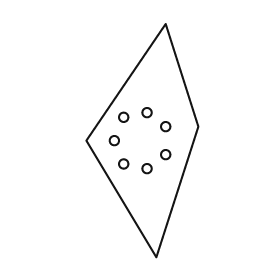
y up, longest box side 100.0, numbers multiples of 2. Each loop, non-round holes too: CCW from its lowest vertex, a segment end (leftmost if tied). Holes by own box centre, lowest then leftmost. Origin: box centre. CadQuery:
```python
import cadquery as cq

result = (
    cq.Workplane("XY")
    .moveTo(6.0, -50.0)
    .lineTo(24.0, 6.0)
    .lineTo(10.0, 50.0)
    .lineTo(-24.0, 0.0)
    .close()
    .moveTo(2.0, -12.0)
    .circle(2.0)
    .moveTo(-8.0, -10.0)
    .circle(2.0)
    .moveTo(10.0, -6.0)
    .circle(2.0)
    .moveTo(-12.0, 0.0)
    .circle(2.0)
    .moveTo(10.0, 6.0)
    .circle(2.0)
    .moveTo(-8.0, 10.0)
    .circle(2.0)
    .moveTo(2.0, 12.0)
    .circle(2.0)
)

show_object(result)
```